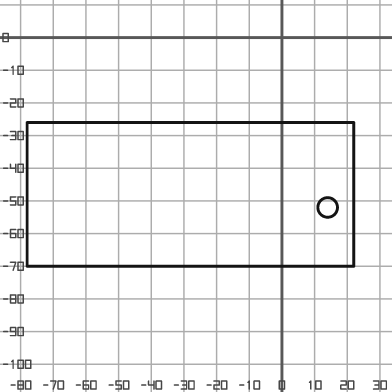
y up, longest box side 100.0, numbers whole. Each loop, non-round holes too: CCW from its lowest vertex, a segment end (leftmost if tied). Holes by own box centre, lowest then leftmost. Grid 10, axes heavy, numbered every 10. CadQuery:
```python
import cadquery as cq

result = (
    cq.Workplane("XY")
    .moveTo(-78.0, -70.0)
    .lineTo(22.0, -70.0)
    .lineTo(22.0, -26.0)
    .lineTo(-78.0, -26.0)
    .close()
    .moveTo(14.0, -52.0)
    .circle(3.0)
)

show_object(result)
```